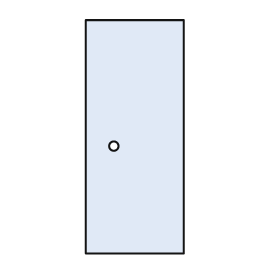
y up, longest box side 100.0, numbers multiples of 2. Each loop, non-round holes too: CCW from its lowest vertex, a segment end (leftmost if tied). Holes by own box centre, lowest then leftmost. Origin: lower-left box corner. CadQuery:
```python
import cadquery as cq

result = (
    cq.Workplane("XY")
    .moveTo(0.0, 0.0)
    .lineTo(42.0, 0.0)
    .lineTo(42.0, 100.0)
    .lineTo(0.0, 100.0)
    .close()
    .moveTo(12.0, 46.0)
    .circle(2.0)
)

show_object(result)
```